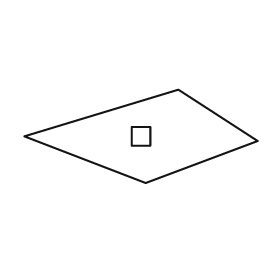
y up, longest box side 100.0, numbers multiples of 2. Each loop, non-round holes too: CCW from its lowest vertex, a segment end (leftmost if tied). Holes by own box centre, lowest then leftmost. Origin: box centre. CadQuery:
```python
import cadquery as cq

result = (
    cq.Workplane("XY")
    .moveTo(2.0, -20.0)
    .lineTo(50.0, -2.0)
    .lineTo(16.0, 20.0)
    .lineTo(-50.0, 0.0)
    .close()
    .moveTo(-4.0, -4.0)
    .lineTo(4.0, -4.0)
    .lineTo(4.0, 4.0)
    .lineTo(-4.0, 4.0)
    .close()
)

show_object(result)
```